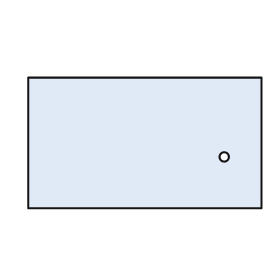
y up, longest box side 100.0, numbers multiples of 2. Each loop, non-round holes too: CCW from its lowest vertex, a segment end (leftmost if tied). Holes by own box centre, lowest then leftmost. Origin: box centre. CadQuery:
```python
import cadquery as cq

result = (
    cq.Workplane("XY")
    .moveTo(-50.0, -28.0)
    .lineTo(50.0, -28.0)
    .lineTo(50.0, 28.0)
    .lineTo(-50.0, 28.0)
    .close()
    .moveTo(34.0, -6.0)
    .circle(2.0)
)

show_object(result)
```